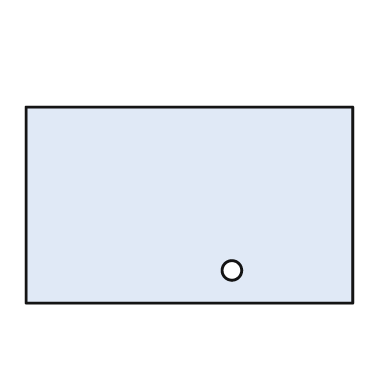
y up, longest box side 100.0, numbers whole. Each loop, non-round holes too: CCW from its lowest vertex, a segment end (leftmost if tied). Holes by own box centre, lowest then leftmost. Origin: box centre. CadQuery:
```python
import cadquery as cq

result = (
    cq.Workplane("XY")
    .moveTo(-50.0, -30.0)
    .lineTo(50.0, -30.0)
    .lineTo(50.0, 30.0)
    .lineTo(-50.0, 30.0)
    .close()
    .moveTo(13.0, -20.0)
    .circle(3.0)
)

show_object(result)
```